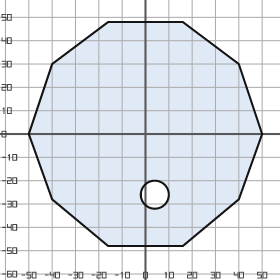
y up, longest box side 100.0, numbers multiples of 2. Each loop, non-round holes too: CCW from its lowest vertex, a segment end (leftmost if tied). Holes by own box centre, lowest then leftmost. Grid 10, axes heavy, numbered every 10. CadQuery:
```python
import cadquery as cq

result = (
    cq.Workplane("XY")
    .moveTo(-16.0, -48.0)
    .lineTo(16.0, -48.0)
    .lineTo(40.0, -28.0)
    .lineTo(50.0, 0.0)
    .lineTo(40.0, 30.0)
    .lineTo(16.0, 48.0)
    .lineTo(-16.0, 48.0)
    .lineTo(-40.0, 30.0)
    .lineTo(-50.0, 0.0)
    .lineTo(-40.0, -28.0)
    .close()
    .moveTo(4.0, -26.0)
    .circle(6.0)
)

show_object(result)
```